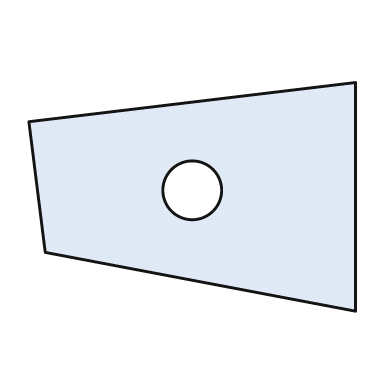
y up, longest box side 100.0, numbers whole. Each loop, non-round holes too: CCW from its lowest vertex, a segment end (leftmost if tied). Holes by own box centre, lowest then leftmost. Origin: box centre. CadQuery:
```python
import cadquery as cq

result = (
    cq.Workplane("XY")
    .moveTo(50.0, -35.0)
    .lineTo(50.0, 35.0)
    .lineTo(-50.0, 23.0)
    .lineTo(-45.0, -17.0)
    .close()
    .moveTo(0.0, 2.0)
    .circle(9.0)
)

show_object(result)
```